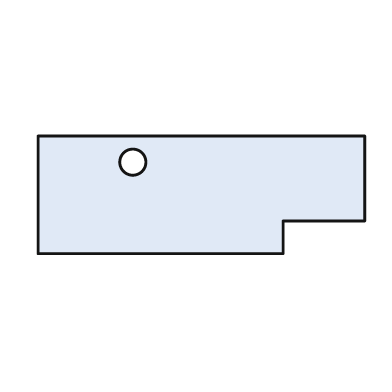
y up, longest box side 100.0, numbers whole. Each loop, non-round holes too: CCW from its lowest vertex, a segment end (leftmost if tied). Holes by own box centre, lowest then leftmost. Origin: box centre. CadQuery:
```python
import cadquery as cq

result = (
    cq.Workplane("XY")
    .moveTo(-50.0, -18.0)
    .lineTo(25.0, -18.0)
    .lineTo(25.0, -8.0)
    .lineTo(50.0, -8.0)
    .lineTo(50.0, 18.0)
    .lineTo(-50.0, 18.0)
    .close()
    .moveTo(-21.0, 10.0)
    .circle(4.0)
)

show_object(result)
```